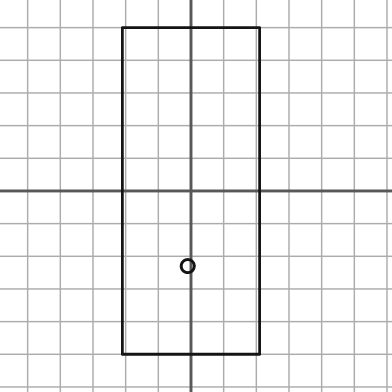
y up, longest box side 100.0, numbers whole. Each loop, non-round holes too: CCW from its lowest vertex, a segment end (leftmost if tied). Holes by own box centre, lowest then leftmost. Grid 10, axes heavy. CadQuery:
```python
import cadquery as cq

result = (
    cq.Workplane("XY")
    .moveTo(-21.0, -50.0)
    .lineTo(21.0, -50.0)
    .lineTo(21.0, 50.0)
    .lineTo(-21.0, 50.0)
    .close()
    .moveTo(-1.0, -23.0)
    .circle(2.0)
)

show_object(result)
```